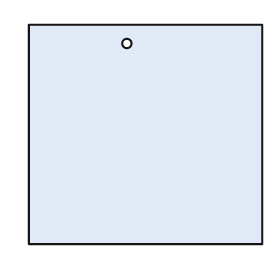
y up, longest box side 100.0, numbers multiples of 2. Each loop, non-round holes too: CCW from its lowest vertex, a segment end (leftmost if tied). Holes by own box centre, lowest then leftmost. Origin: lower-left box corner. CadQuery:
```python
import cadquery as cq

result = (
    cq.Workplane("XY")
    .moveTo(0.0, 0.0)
    .lineTo(100.0, 0.0)
    .lineTo(100.0, 94.0)
    .lineTo(0.0, 94.0)
    .close()
    .moveTo(42.0, 86.0)
    .circle(2.0)
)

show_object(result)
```